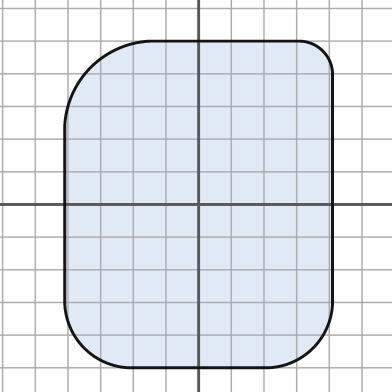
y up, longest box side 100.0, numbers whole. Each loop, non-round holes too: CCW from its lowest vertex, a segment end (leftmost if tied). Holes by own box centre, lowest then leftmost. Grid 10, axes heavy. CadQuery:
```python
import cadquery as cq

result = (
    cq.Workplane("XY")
    .moveTo(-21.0, -50.0)
    .lineTo(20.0, -50.0)
    .threePointArc((35.0, -44.0), (41.0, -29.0))
    .lineTo(41.0, 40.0)
    .threePointArc((38.0, 47.0), (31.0, 50.0))
    .lineTo(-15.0, 50.0)
    .threePointArc((-33.0, 42.0), (-41.0, 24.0))
    .lineTo(-41.0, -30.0)
    .threePointArc((-35.0, -44.0), (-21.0, -50.0))
    .close()
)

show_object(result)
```